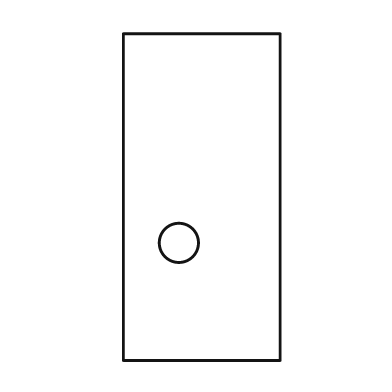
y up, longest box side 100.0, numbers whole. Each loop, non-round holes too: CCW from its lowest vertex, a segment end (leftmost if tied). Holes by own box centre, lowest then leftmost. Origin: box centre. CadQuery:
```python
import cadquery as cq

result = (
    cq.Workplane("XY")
    .moveTo(-24.0, -50.0)
    .lineTo(24.0, -50.0)
    .lineTo(24.0, 50.0)
    .lineTo(-24.0, 50.0)
    .close()
    .moveTo(-7.0, -14.0)
    .circle(6.0)
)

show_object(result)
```